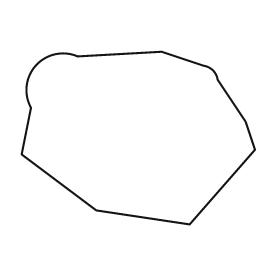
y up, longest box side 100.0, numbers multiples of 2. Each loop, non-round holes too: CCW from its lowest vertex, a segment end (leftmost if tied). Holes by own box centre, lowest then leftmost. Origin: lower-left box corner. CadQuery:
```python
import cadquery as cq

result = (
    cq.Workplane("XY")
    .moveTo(72.0, 0.0)
    .lineTo(100.0, 32.0)
    .lineTo(96.0, 44.0)
    .lineTo(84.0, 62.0)
    .threePointArc((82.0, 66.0), (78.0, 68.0))
    .lineTo(60.0, 74.0)
    .lineTo(24.0, 72.0)
    .threePointArc((6.0, 68.0), (4.0, 50.0))
    .lineTo(0.0, 30.0)
    .lineTo(32.0, 6.0)
    .close()
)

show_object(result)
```